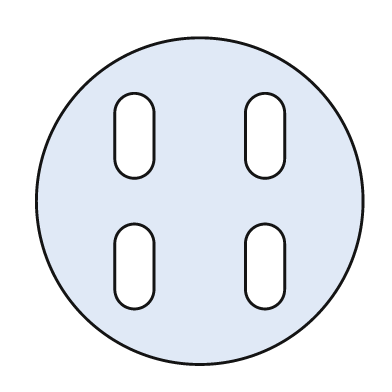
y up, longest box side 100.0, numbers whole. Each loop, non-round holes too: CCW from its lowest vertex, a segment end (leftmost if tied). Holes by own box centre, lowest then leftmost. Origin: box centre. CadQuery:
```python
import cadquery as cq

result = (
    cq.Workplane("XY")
    .moveTo(0.0, 0.0)
    .circle(50.0)
    .moveTo(-26.0, -27.0)
    .threePointArc((-20.0, -33.0), (-14.0, -27.0))
    .lineTo(-14.0, -13.0)
    .threePointArc((-20.0, -7.0), (-26.0, -13.0))
    .close()
    .moveTo(14.0, -27.0)
    .threePointArc((20.0, -33.0), (26.0, -27.0))
    .lineTo(26.0, -13.0)
    .threePointArc((20.0, -7.0), (14.0, -13.0))
    .close()
    .moveTo(-26.0, 13.0)
    .threePointArc((-20.0, 7.0), (-14.0, 13.0))
    .lineTo(-14.0, 27.0)
    .threePointArc((-20.0, 33.0), (-26.0, 27.0))
    .close()
    .moveTo(14.0, 13.0)
    .threePointArc((20.0, 7.0), (26.0, 13.0))
    .lineTo(26.0, 27.0)
    .threePointArc((20.0, 33.0), (14.0, 27.0))
    .close()
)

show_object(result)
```